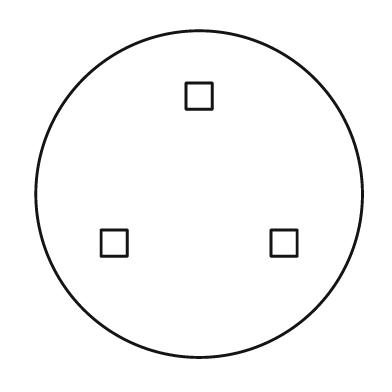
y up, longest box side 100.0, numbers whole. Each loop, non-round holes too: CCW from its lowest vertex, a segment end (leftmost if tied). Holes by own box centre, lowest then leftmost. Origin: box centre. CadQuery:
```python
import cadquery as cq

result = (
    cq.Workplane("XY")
    .moveTo(0.0, 0.0)
    .circle(50.0)
    .moveTo(-30.0, -19.0)
    .lineTo(-22.0, -19.0)
    .lineTo(-22.0, -11.0)
    .lineTo(-30.0, -11.0)
    .close()
    .moveTo(22.0, -19.0)
    .lineTo(30.0, -19.0)
    .lineTo(30.0, -11.0)
    .lineTo(22.0, -11.0)
    .close()
    .moveTo(-4.0, 26.0)
    .lineTo(4.0, 26.0)
    .lineTo(4.0, 34.0)
    .lineTo(-4.0, 34.0)
    .close()
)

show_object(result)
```